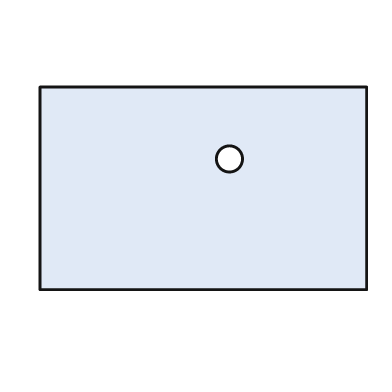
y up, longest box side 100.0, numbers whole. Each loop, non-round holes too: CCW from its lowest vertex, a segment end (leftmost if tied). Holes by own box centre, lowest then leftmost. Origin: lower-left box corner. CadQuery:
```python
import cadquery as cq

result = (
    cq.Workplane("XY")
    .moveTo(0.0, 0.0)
    .lineTo(100.0, 0.0)
    .lineTo(100.0, 62.0)
    .lineTo(0.0, 62.0)
    .close()
    .moveTo(58.0, 40.0)
    .circle(4.0)
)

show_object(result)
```